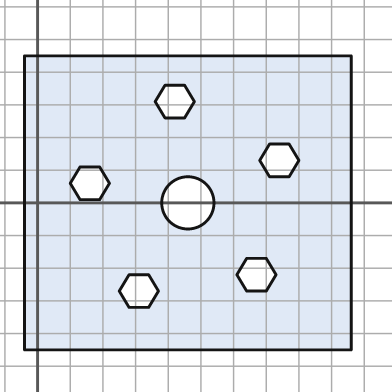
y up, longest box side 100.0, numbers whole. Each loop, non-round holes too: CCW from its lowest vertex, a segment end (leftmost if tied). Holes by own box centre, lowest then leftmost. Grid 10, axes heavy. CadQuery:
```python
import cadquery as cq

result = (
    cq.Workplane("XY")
    .moveTo(-4.0, -45.0)
    .lineTo(96.0, -45.0)
    .lineTo(96.0, 45.0)
    .lineTo(-4.0, 45.0)
    .close()
    .moveTo(28.0, -32.0)
    .lineTo(34.0, -32.0)
    .lineTo(37.0, -27.0)
    .lineTo(34.0, -22.0)
    .lineTo(28.0, -22.0)
    .lineTo(25.0, -27.0)
    .close()
    .moveTo(64.0, -27.0)
    .lineTo(70.0, -27.0)
    .lineTo(73.0, -22.0)
    .lineTo(70.0, -17.0)
    .lineTo(64.0, -17.0)
    .lineTo(61.0, -22.0)
    .close()
    .moveTo(46.0, 0.0)
    .circle(8.0)
    .moveTo(13.0, 1.0)
    .lineTo(19.0, 1.0)
    .lineTo(22.0, 6.0)
    .lineTo(19.0, 11.0)
    .lineTo(13.0, 11.0)
    .lineTo(10.0, 6.0)
    .close()
    .moveTo(71.0, 8.0)
    .lineTo(77.0, 8.0)
    .lineTo(80.0, 13.0)
    .lineTo(77.0, 18.0)
    .lineTo(71.0, 18.0)
    .lineTo(68.0, 13.0)
    .close()
    .moveTo(39.0, 26.0)
    .lineTo(45.0, 26.0)
    .lineTo(48.0, 31.0)
    .lineTo(45.0, 36.0)
    .lineTo(39.0, 36.0)
    .lineTo(36.0, 31.0)
    .close()
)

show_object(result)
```